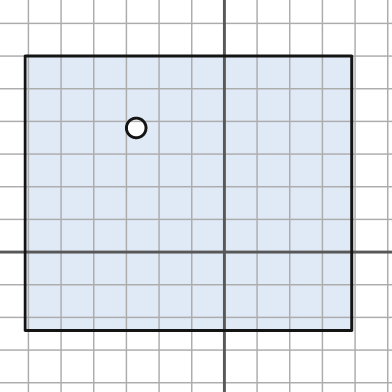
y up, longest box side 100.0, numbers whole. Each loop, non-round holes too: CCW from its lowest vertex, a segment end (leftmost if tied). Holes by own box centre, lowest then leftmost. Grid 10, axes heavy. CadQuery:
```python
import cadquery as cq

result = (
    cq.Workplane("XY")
    .moveTo(-61.0, -24.0)
    .lineTo(39.0, -24.0)
    .lineTo(39.0, 60.0)
    .lineTo(-61.0, 60.0)
    .close()
    .moveTo(-27.0, 38.0)
    .circle(3.0)
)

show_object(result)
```